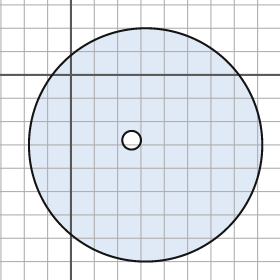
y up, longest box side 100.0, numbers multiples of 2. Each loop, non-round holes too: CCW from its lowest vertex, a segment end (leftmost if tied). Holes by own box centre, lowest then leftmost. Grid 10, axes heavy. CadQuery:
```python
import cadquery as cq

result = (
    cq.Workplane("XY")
    .moveTo(32.0, -30.0)
    .circle(50.0)
    .moveTo(26.0, -28.0)
    .circle(4.0)
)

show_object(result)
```